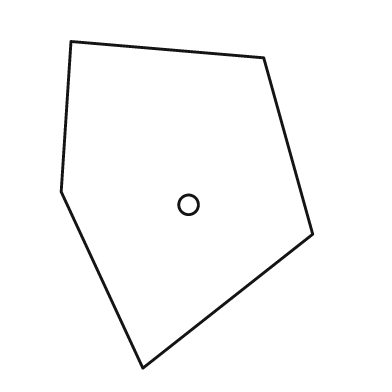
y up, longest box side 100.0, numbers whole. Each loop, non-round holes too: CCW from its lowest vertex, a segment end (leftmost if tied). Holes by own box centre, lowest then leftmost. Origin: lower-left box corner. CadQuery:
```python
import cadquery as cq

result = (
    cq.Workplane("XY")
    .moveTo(25.0, 0.0)
    .lineTo(77.0, 41.0)
    .lineTo(62.0, 95.0)
    .lineTo(3.0, 100.0)
    .lineTo(0.0, 54.0)
    .close()
    .moveTo(39.0, 50.0)
    .circle(3.0)
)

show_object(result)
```